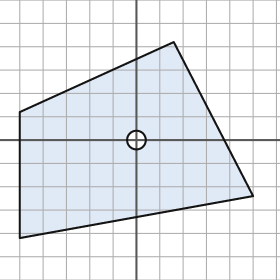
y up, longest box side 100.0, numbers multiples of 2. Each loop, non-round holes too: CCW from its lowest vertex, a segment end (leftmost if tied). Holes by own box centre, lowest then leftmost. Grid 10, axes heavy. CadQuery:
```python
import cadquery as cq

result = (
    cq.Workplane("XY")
    .moveTo(-50.0, -42.0)
    .lineTo(50.0, -24.0)
    .lineTo(16.0, 42.0)
    .lineTo(-50.0, 12.0)
    .close()
    .moveTo(0.0, 0.0)
    .circle(4.0)
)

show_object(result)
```